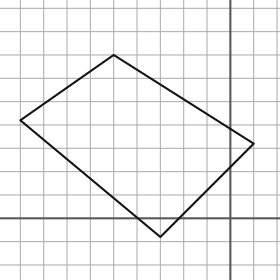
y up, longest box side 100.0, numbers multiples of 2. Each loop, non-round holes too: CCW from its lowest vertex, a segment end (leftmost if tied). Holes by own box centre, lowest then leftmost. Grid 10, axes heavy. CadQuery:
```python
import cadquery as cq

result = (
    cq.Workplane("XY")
    .moveTo(-30.0, -8.0)
    .lineTo(10.0, 32.0)
    .lineTo(-50.0, 70.0)
    .lineTo(-90.0, 42.0)
    .close()
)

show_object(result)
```